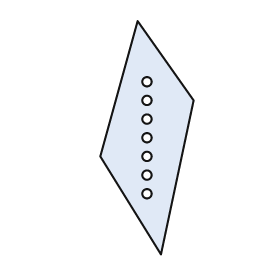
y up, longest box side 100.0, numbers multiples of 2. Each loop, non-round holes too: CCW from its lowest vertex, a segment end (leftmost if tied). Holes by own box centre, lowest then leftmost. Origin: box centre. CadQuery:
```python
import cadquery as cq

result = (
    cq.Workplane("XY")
    .moveTo(6.0, -50.0)
    .lineTo(20.0, 16.0)
    .lineTo(-4.0, 50.0)
    .lineTo(-20.0, -8.0)
    .close()
    .moveTo(0.0, -24.0)
    .circle(2.0)
    .moveTo(0.0, -16.0)
    .circle(2.0)
    .moveTo(0.0, -8.0)
    .circle(2.0)
    .moveTo(0.0, 0.0)
    .circle(2.0)
    .moveTo(0.0, 8.0)
    .circle(2.0)
    .moveTo(0.0, 16.0)
    .circle(2.0)
    .moveTo(0.0, 24.0)
    .circle(2.0)
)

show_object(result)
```